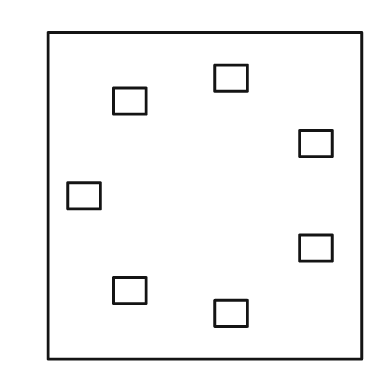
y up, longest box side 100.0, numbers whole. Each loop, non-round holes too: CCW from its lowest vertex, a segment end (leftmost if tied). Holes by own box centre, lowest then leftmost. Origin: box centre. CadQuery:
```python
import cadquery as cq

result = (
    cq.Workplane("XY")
    .moveTo(-48.0, -50.0)
    .lineTo(48.0, -50.0)
    .lineTo(48.0, 50.0)
    .lineTo(-48.0, 50.0)
    .close()
    .moveTo(3.0, -40.0)
    .lineTo(13.0, -40.0)
    .lineTo(13.0, -32.0)
    .lineTo(3.0, -32.0)
    .close()
    .moveTo(-28.0, -33.0)
    .lineTo(-18.0, -33.0)
    .lineTo(-18.0, -25.0)
    .lineTo(-28.0, -25.0)
    .close()
    .moveTo(29.0, -20.0)
    .lineTo(39.0, -20.0)
    .lineTo(39.0, -12.0)
    .lineTo(29.0, -12.0)
    .close()
    .moveTo(-42.0, -4.0)
    .lineTo(-32.0, -4.0)
    .lineTo(-32.0, 4.0)
    .lineTo(-42.0, 4.0)
    .close()
    .moveTo(29.0, 12.0)
    .lineTo(39.0, 12.0)
    .lineTo(39.0, 20.0)
    .lineTo(29.0, 20.0)
    .close()
    .moveTo(-28.0, 25.0)
    .lineTo(-18.0, 25.0)
    .lineTo(-18.0, 33.0)
    .lineTo(-28.0, 33.0)
    .close()
    .moveTo(3.0, 32.0)
    .lineTo(13.0, 32.0)
    .lineTo(13.0, 40.0)
    .lineTo(3.0, 40.0)
    .close()
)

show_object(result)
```